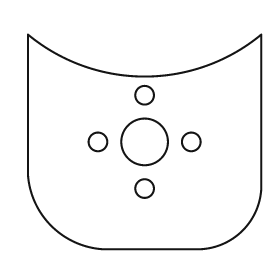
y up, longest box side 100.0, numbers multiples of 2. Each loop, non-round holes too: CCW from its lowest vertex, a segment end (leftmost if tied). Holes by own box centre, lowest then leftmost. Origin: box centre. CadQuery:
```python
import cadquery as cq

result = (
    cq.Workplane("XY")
    .moveTo(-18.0, -46.0)
    .lineTo(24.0, -46.0)
    .threePointArc((42.0, -38.0), (50.0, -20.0))
    .lineTo(50.0, 46.0)
    .threePointArc((0.0, 28.0), (-50.0, 46.0))
    .lineTo(-50.0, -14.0)
    .threePointArc((-40.0, -36.0), (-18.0, -46.0))
    .close()
    .moveTo(0.0, -20.0)
    .circle(4.0)
    .moveTo(-20.0, 0.0)
    .circle(4.0)
    .moveTo(0.0, 0.0)
    .circle(10.0)
    .moveTo(20.0, 0.0)
    .circle(4.0)
    .moveTo(0.0, 20.0)
    .circle(4.0)
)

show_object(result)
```